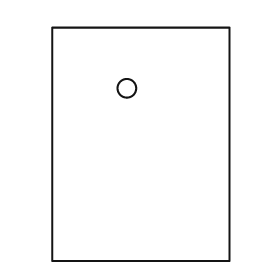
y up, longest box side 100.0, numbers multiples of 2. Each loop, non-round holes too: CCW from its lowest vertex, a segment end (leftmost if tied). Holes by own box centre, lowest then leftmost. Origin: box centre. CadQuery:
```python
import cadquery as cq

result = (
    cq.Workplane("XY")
    .moveTo(-38.0, -50.0)
    .lineTo(38.0, -50.0)
    .lineTo(38.0, 50.0)
    .lineTo(-38.0, 50.0)
    .close()
    .moveTo(-6.0, 24.0)
    .circle(4.0)
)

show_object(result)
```